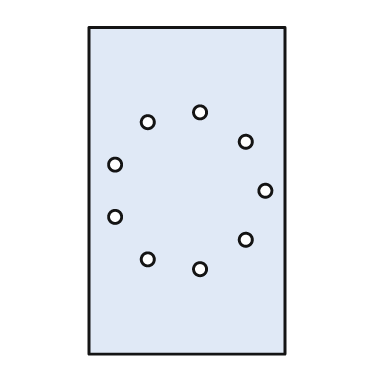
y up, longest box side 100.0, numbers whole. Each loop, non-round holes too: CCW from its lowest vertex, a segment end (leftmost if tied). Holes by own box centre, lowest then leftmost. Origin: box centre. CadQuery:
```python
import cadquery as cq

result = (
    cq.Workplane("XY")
    .moveTo(-30.0, -50.0)
    .lineTo(30.0, -50.0)
    .lineTo(30.0, 50.0)
    .lineTo(-30.0, 50.0)
    .close()
    .moveTo(4.0, -24.0)
    .circle(2.0)
    .moveTo(-12.0, -21.0)
    .circle(2.0)
    .moveTo(18.0, -15.0)
    .circle(2.0)
    .moveTo(-22.0, -8.0)
    .circle(2.0)
    .moveTo(24.0, 0.0)
    .circle(2.0)
    .moveTo(-22.0, 8.0)
    .circle(2.0)
    .moveTo(18.0, 15.0)
    .circle(2.0)
    .moveTo(-12.0, 21.0)
    .circle(2.0)
    .moveTo(4.0, 24.0)
    .circle(2.0)
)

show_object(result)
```